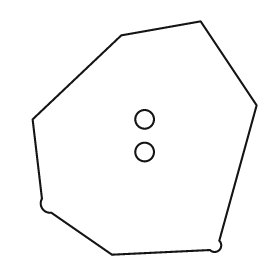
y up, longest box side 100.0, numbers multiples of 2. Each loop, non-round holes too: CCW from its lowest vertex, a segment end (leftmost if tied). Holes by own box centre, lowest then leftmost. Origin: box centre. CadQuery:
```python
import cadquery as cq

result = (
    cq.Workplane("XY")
    .moveTo(-14.0, -50.0)
    .lineTo(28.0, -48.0)
    .threePointArc((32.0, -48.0), (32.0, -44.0))
    .lineTo(48.0, 14.0)
    .lineTo(24.0, 50.0)
    .lineTo(-10.0, 44.0)
    .lineTo(-48.0, 8.0)
    .lineTo(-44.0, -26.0)
    .threePointArc((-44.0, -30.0), (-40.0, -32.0))
    .close()
    .moveTo(0.0, -6.0)
    .circle(4.0)
    .moveTo(0.0, 8.0)
    .circle(4.0)
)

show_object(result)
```